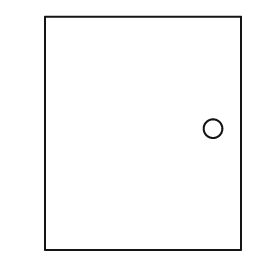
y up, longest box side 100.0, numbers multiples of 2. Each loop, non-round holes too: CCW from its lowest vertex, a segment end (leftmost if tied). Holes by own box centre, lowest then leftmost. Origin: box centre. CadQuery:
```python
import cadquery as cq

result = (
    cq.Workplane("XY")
    .moveTo(-42.0, -50.0)
    .lineTo(42.0, -50.0)
    .lineTo(42.0, 50.0)
    .lineTo(-42.0, 50.0)
    .close()
    .moveTo(30.0, 2.0)
    .circle(4.0)
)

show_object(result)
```